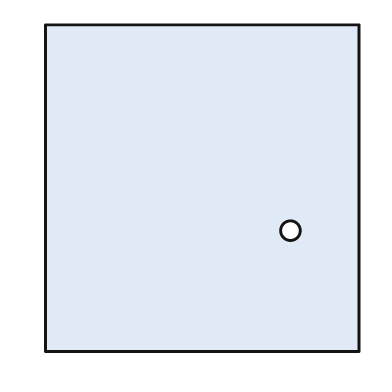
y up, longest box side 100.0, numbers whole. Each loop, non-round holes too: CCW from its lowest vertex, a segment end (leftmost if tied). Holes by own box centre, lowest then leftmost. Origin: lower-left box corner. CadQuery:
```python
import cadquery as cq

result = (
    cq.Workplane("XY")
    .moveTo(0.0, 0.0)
    .lineTo(96.0, 0.0)
    .lineTo(96.0, 100.0)
    .lineTo(0.0, 100.0)
    .close()
    .moveTo(75.0, 37.0)
    .circle(3.0)
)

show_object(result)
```